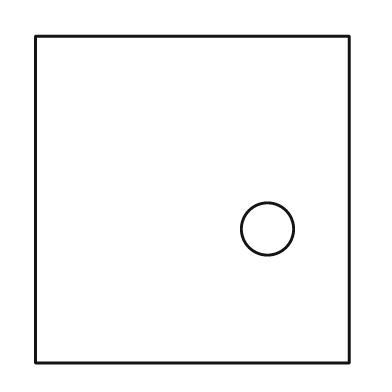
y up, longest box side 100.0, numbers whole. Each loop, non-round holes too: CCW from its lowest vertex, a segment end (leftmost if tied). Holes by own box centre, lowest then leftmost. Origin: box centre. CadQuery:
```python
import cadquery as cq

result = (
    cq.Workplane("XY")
    .moveTo(-48.0, -50.0)
    .lineTo(48.0, -50.0)
    .lineTo(48.0, 50.0)
    .lineTo(-48.0, 50.0)
    .close()
    .moveTo(23.0, -9.0)
    .circle(8.0)
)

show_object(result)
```